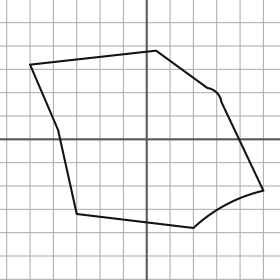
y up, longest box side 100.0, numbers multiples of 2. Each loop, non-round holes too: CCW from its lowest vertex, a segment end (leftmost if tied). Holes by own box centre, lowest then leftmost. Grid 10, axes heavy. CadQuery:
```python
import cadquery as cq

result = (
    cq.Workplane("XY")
    .moveTo(20.0, -38.0)
    .threePointArc((34.0, -28.0), (50.0, -22.0))
    .lineTo(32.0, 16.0)
    .threePointArc((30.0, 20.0), (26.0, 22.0))
    .lineTo(4.0, 38.0)
    .lineTo(-50.0, 32.0)
    .lineTo(-38.0, 4.0)
    .lineTo(-30.0, -32.0)
    .close()
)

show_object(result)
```